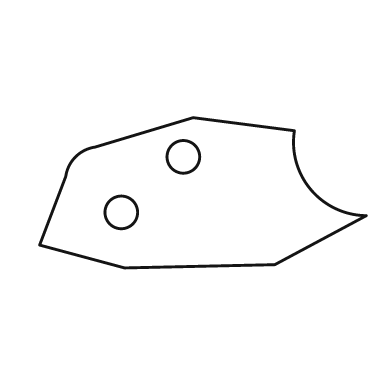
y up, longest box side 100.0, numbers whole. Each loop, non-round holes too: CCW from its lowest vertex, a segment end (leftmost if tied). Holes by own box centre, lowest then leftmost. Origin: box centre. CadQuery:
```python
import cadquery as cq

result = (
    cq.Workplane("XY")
    .moveTo(-24.0, -23.0)
    .lineTo(22.0, -22.0)
    .lineTo(50.0, -7.0)
    .threePointArc((33.0, 1.0), (28.0, 19.0))
    .lineTo(-3.0, 23.0)
    .lineTo(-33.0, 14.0)
    .threePointArc((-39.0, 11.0), (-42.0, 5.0))
    .lineTo(-50.0, -16.0)
    .close()
    .moveTo(-25.0, -6.0)
    .circle(5.0)
    .moveTo(-6.0, 11.0)
    .circle(5.0)
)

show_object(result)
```